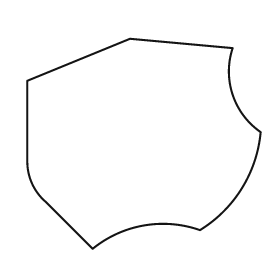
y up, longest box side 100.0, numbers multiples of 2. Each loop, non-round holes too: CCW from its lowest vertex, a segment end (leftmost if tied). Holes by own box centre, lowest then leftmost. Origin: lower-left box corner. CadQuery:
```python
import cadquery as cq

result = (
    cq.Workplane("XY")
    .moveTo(28.0, 0.0)
    .threePointArc((50.0, 10.0), (74.0, 8.0))
    .threePointArc((92.0, 26.0), (100.0, 50.0))
    .threePointArc((88.0, 66.0), (88.0, 86.0))
    .lineTo(44.0, 90.0)
    .lineTo(0.0, 72.0)
    .lineTo(0.0, 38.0)
    .threePointArc((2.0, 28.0), (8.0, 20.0))
    .close()
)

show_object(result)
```